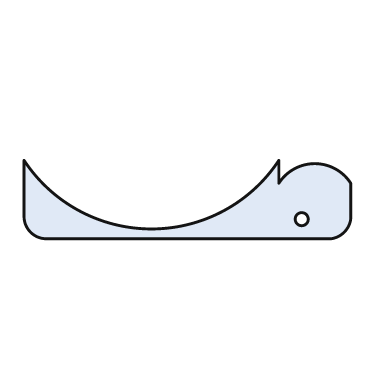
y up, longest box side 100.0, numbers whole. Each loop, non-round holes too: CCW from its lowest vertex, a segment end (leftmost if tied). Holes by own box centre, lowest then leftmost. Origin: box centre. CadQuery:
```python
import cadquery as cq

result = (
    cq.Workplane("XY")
    .moveTo(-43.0, -12.0)
    .lineTo(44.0, -12.0)
    .threePointArc((48.0, -10.0), (50.0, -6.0))
    .lineTo(50.0, 5.0)
    .threePointArc((39.0, 11.0), (28.0, 5.0))
    .lineTo(28.0, 12.0)
    .threePointArc((-11.0, -9.0), (-50.0, 12.0))
    .lineTo(-50.0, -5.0)
    .threePointArc((-48.0, -10.0), (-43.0, -12.0))
    .close()
    .moveTo(35.0, -6.0)
    .circle(2.0)
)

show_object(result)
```